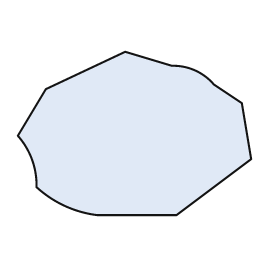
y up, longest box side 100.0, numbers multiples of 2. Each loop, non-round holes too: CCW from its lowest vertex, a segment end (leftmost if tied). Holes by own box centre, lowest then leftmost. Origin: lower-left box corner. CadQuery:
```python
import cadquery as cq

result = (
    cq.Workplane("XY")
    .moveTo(34.0, 0.0)
    .lineTo(68.0, 0.0)
    .lineTo(100.0, 24.0)
    .lineTo(96.0, 48.0)
    .lineTo(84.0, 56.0)
    .threePointArc((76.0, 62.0), (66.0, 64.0))
    .lineTo(46.0, 70.0)
    .lineTo(12.0, 54.0)
    .lineTo(0.0, 34.0)
    .threePointArc((6.0, 24.0), (8.0, 12.0))
    .threePointArc((20.0, 4.0), (34.0, 0.0))
    .close()
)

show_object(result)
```